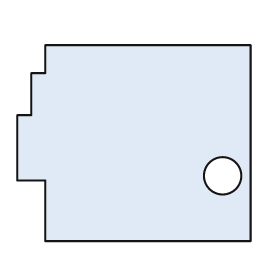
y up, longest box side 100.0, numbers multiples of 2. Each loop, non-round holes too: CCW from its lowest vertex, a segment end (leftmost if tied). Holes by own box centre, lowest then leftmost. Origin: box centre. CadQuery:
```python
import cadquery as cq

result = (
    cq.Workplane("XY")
    .moveTo(-38.0, -42.0)
    .lineTo(50.0, -42.0)
    .lineTo(50.0, 42.0)
    .lineTo(-38.0, 42.0)
    .lineTo(-38.0, 30.0)
    .lineTo(-44.0, 30.0)
    .lineTo(-44.0, 12.0)
    .lineTo(-50.0, 12.0)
    .lineTo(-50.0, -16.0)
    .lineTo(-38.0, -16.0)
    .close()
    .moveTo(38.0, -14.0)
    .circle(8.0)
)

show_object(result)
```